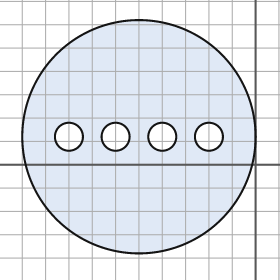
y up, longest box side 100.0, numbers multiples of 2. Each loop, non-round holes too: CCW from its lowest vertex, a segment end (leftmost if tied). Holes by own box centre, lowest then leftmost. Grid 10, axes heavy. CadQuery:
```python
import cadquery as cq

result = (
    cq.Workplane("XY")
    .moveTo(-50.0, 12.0)
    .circle(50.0)
    .moveTo(-80.0, 12.0)
    .circle(6.0)
    .moveTo(-60.0, 12.0)
    .circle(6.0)
    .moveTo(-40.0, 12.0)
    .circle(6.0)
    .moveTo(-20.0, 12.0)
    .circle(6.0)
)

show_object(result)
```